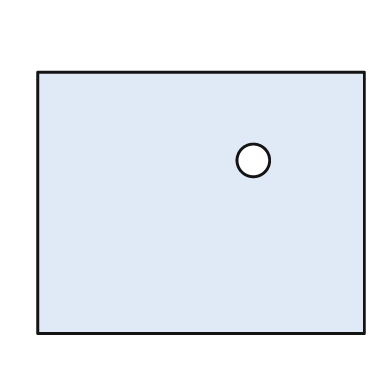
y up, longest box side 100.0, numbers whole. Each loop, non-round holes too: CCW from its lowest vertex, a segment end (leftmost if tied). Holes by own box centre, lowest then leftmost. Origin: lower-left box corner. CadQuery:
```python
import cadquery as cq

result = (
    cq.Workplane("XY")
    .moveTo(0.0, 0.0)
    .lineTo(100.0, 0.0)
    .lineTo(100.0, 80.0)
    .lineTo(0.0, 80.0)
    .close()
    .moveTo(66.0, 53.0)
    .circle(5.0)
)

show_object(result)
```